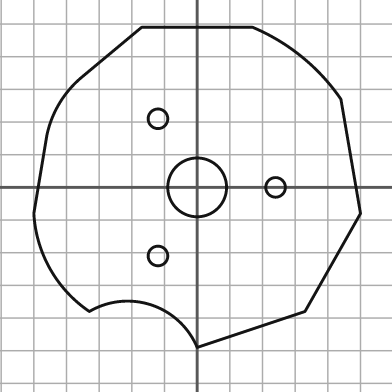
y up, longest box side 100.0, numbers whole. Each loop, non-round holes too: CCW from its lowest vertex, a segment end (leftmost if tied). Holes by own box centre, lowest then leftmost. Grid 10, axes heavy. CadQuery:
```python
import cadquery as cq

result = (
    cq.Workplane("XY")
    .moveTo(0.0, -49.0)
    .lineTo(33.0, -38.0)
    .lineTo(50.0, -8.0)
    .lineTo(44.0, 27.0)
    .threePointArc((32.0, 40.0), (17.0, 49.0))
    .lineTo(-17.0, 49.0)
    .lineTo(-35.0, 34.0)
    .threePointArc((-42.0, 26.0), (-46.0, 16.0))
    .lineTo(-50.0, -8.0)
    .threePointArc((-45.0, -25.0), (-33.0, -38.0))
    .threePointArc((-14.0, -36.0), (0.0, -49.0))
    .close()
    .moveTo(-12.0, -21.0)
    .circle(3.0)
    .moveTo(0.0, 0.0)
    .circle(9.0)
    .moveTo(24.0, 0.0)
    .circle(3.0)
    .moveTo(-12.0, 21.0)
    .circle(3.0)
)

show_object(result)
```